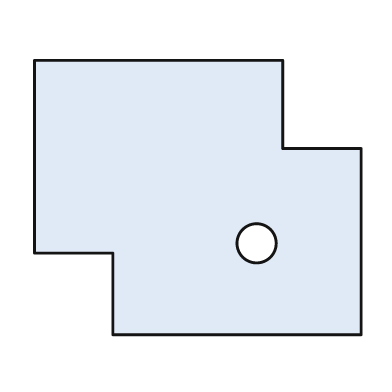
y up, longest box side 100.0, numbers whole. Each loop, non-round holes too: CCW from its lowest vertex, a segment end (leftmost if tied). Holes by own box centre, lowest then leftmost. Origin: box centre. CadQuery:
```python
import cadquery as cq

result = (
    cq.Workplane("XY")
    .moveTo(-26.0, -42.0)
    .lineTo(50.0, -42.0)
    .lineTo(50.0, 15.0)
    .lineTo(26.0, 15.0)
    .lineTo(26.0, 42.0)
    .lineTo(-50.0, 42.0)
    .lineTo(-50.0, -17.0)
    .lineTo(-26.0, -17.0)
    .close()
    .moveTo(18.0, -14.0)
    .circle(6.0)
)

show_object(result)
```